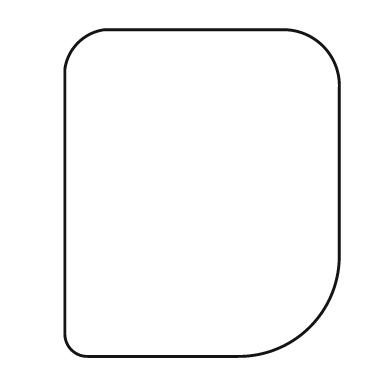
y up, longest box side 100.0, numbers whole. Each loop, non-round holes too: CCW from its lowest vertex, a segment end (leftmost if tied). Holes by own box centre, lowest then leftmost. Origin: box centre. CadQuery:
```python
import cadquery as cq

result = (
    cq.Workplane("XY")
    .moveTo(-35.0, -50.0)
    .lineTo(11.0, -50.0)
    .threePointArc((33.0, -41.0), (42.0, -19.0))
    .lineTo(42.0, 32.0)
    .threePointArc((37.0, 45.0), (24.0, 50.0))
    .lineTo(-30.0, 50.0)
    .threePointArc((-38.0, 46.0), (-42.0, 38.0))
    .lineTo(-42.0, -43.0)
    .threePointArc((-40.0, -48.0), (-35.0, -50.0))
    .close()
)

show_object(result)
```